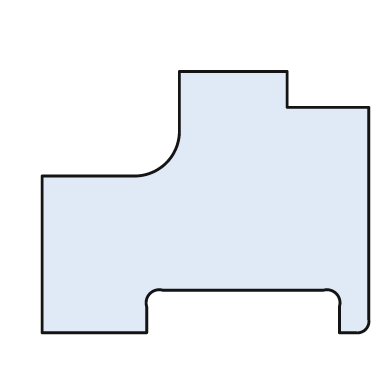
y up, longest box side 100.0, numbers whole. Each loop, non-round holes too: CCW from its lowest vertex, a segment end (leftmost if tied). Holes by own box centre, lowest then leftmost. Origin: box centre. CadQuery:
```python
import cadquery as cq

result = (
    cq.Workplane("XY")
    .moveTo(-50.0, -40.0)
    .lineTo(-18.0, -40.0)
    .lineTo(-18.0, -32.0)
    .threePointArc((-17.0, -28.0), (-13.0, -27.0))
    .lineTo(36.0, -27.0)
    .threePointArc((40.0, -28.0), (41.0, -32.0))
    .lineTo(41.0, -40.0)
    .lineTo(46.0, -40.0)
    .threePointArc((49.0, -39.0), (50.0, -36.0))
    .lineTo(50.0, 29.0)
    .lineTo(25.0, 29.0)
    .lineTo(25.0, 40.0)
    .lineTo(-8.0, 40.0)
    .lineTo(-8.0, 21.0)
    .threePointArc((-12.0, 12.0), (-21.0, 8.0))
    .lineTo(-50.0, 8.0)
    .close()
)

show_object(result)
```